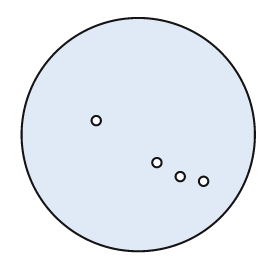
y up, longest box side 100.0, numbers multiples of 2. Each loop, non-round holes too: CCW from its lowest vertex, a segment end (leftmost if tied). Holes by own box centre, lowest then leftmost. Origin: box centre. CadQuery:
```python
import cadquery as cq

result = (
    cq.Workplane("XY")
    .moveTo(0.0, 0.0)
    .circle(50.0)
    .moveTo(28.0, -20.0)
    .circle(2.0)
    .moveTo(18.0, -18.0)
    .circle(2.0)
    .moveTo(8.0, -12.0)
    .circle(2.0)
    .moveTo(-18.0, 6.0)
    .circle(2.0)
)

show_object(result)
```